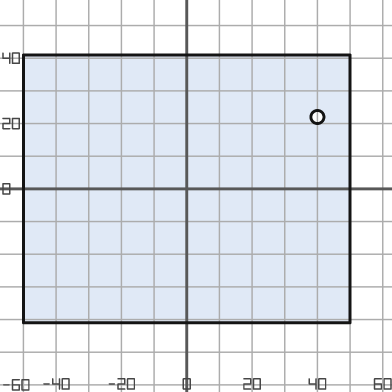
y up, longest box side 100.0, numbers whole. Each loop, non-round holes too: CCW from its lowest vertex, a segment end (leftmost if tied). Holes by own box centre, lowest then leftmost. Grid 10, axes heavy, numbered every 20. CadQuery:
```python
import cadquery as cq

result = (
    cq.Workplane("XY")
    .moveTo(-50.0, -41.0)
    .lineTo(50.0, -41.0)
    .lineTo(50.0, 41.0)
    .lineTo(-50.0, 41.0)
    .close()
    .moveTo(40.0, 22.0)
    .circle(2.0)
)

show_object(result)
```